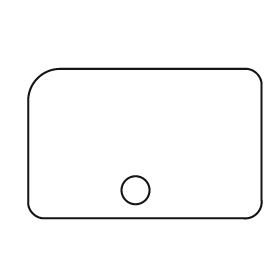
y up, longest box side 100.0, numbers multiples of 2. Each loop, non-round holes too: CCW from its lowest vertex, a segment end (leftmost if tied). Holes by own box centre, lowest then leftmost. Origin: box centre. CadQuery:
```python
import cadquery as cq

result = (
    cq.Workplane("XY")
    .moveTo(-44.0, -32.0)
    .lineTo(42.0, -32.0)
    .threePointArc((48.0, -30.0), (50.0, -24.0))
    .lineTo(50.0, 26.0)
    .threePointArc((48.0, 30.0), (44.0, 32.0))
    .lineTo(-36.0, 32.0)
    .threePointArc((-46.0, 28.0), (-50.0, 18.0))
    .lineTo(-50.0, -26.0)
    .threePointArc((-48.0, -30.0), (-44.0, -32.0))
    .close()
    .moveTo(-4.0, -20.0)
    .circle(6.0)
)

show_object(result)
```